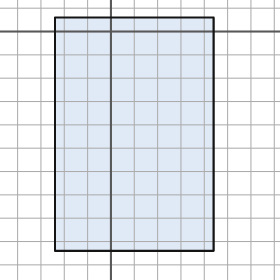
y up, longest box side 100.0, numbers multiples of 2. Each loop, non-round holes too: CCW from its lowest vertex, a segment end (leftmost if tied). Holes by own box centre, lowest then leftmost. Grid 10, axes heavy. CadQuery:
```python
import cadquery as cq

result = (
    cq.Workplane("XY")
    .moveTo(-24.0, -94.0)
    .lineTo(44.0, -94.0)
    .lineTo(44.0, 6.0)
    .lineTo(-24.0, 6.0)
    .close()
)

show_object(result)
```